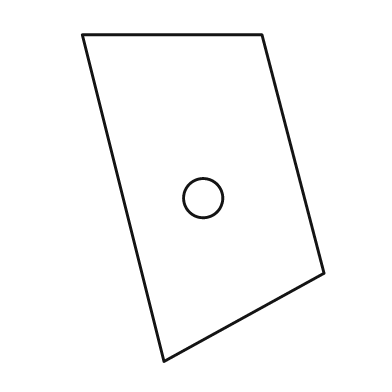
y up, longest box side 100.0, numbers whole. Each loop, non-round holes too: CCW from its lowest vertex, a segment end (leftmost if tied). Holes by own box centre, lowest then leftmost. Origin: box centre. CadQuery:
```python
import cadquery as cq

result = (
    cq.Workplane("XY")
    .moveTo(-12.0, -50.0)
    .lineTo(37.0, -23.0)
    .lineTo(18.0, 50.0)
    .lineTo(-37.0, 50.0)
    .close()
    .moveTo(0.0, 0.0)
    .circle(6.0)
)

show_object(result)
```